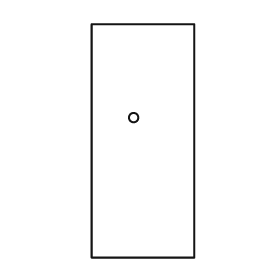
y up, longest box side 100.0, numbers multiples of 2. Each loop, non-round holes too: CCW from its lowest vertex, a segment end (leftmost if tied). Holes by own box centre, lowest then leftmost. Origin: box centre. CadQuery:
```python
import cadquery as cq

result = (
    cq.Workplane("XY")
    .moveTo(-22.0, -50.0)
    .lineTo(22.0, -50.0)
    .lineTo(22.0, 50.0)
    .lineTo(-22.0, 50.0)
    .close()
    .moveTo(-4.0, 10.0)
    .circle(2.0)
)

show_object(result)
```